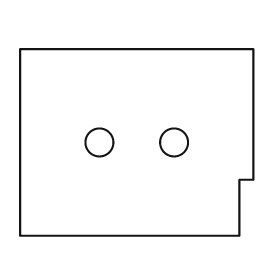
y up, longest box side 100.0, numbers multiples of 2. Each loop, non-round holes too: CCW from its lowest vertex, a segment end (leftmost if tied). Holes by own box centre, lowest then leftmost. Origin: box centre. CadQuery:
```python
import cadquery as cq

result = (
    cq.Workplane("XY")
    .moveTo(-50.0, -40.0)
    .lineTo(44.0, -40.0)
    .lineTo(44.0, -16.0)
    .lineTo(50.0, -16.0)
    .lineTo(50.0, 40.0)
    .lineTo(-50.0, 40.0)
    .close()
    .moveTo(-16.0, 0.0)
    .circle(6.0)
    .moveTo(16.0, 0.0)
    .circle(6.0)
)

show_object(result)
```